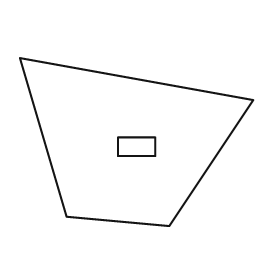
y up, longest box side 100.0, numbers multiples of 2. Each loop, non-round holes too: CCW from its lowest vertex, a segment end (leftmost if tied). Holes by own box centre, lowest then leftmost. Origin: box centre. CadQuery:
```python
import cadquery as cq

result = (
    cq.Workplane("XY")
    .moveTo(14.0, -36.0)
    .lineTo(50.0, 18.0)
    .lineTo(-50.0, 36.0)
    .lineTo(-30.0, -32.0)
    .close()
    .moveTo(-8.0, -6.0)
    .lineTo(8.0, -6.0)
    .lineTo(8.0, 2.0)
    .lineTo(-8.0, 2.0)
    .close()
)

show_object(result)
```